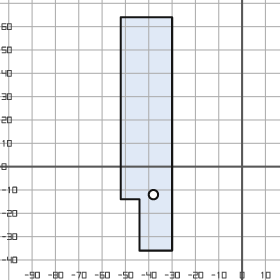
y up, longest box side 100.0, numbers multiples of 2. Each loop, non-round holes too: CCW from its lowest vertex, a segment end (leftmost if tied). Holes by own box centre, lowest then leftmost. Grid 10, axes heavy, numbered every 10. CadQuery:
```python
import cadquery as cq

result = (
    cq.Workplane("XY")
    .moveTo(-44.0, -36.0)
    .lineTo(-30.0, -36.0)
    .lineTo(-30.0, 64.0)
    .lineTo(-52.0, 64.0)
    .lineTo(-52.0, -14.0)
    .lineTo(-44.0, -14.0)
    .close()
    .moveTo(-38.0, -12.0)
    .circle(2.0)
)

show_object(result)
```